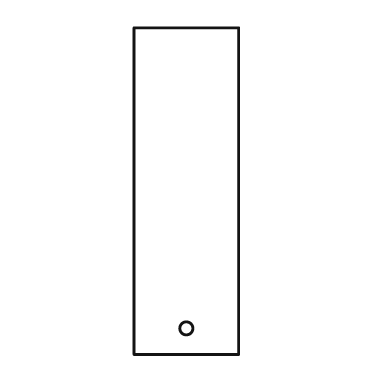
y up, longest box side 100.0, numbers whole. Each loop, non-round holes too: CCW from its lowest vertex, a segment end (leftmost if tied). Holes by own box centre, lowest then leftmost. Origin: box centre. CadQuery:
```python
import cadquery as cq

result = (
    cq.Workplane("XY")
    .moveTo(-16.0, -50.0)
    .lineTo(16.0, -50.0)
    .lineTo(16.0, 50.0)
    .lineTo(-16.0, 50.0)
    .close()
    .moveTo(0.0, -42.0)
    .circle(2.0)
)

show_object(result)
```